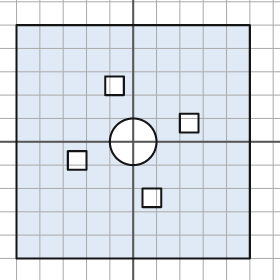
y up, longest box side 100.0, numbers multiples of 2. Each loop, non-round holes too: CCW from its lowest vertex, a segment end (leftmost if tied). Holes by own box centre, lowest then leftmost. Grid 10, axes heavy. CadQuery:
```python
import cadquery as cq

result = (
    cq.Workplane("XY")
    .moveTo(-50.0, -50.0)
    .lineTo(50.0, -50.0)
    .lineTo(50.0, 50.0)
    .lineTo(-50.0, 50.0)
    .close()
    .moveTo(4.0, -28.0)
    .lineTo(12.0, -28.0)
    .lineTo(12.0, -20.0)
    .lineTo(4.0, -20.0)
    .close()
    .moveTo(-28.0, -12.0)
    .lineTo(-20.0, -12.0)
    .lineTo(-20.0, -4.0)
    .lineTo(-28.0, -4.0)
    .close()
    .moveTo(0.0, 0.0)
    .circle(10.0)
    .moveTo(20.0, 4.0)
    .lineTo(28.0, 4.0)
    .lineTo(28.0, 12.0)
    .lineTo(20.0, 12.0)
    .close()
    .moveTo(-12.0, 20.0)
    .lineTo(-4.0, 20.0)
    .lineTo(-4.0, 28.0)
    .lineTo(-12.0, 28.0)
    .close()
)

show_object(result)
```